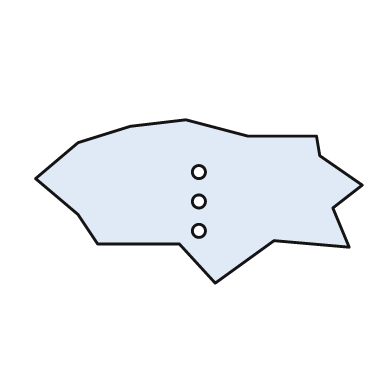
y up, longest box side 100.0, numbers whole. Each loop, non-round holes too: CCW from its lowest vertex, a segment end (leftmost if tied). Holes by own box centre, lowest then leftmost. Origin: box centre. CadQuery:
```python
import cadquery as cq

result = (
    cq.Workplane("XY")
    .moveTo(5.0, -25.0)
    .lineTo(23.0, -12.0)
    .lineTo(46.0, -14.0)
    .lineTo(41.0, -2.0)
    .lineTo(50.0, 5.0)
    .lineTo(37.0, 14.0)
    .lineTo(36.0, 20.0)
    .lineTo(15.0, 20.0)
    .lineTo(-4.0, 25.0)
    .lineTo(-21.0, 23.0)
    .lineTo(-37.0, 18.0)
    .lineTo(-50.0, 7.0)
    .lineTo(-37.0, -4.0)
    .lineTo(-31.0, -13.0)
    .lineTo(-6.0, -13.0)
    .close()
    .moveTo(0.0, -9.0)
    .circle(2.0)
    .moveTo(0.0, 0.0)
    .circle(2.0)
    .moveTo(0.0, 9.0)
    .circle(2.0)
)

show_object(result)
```